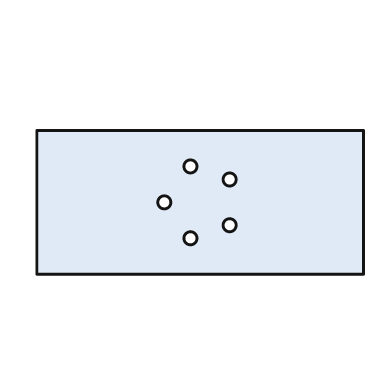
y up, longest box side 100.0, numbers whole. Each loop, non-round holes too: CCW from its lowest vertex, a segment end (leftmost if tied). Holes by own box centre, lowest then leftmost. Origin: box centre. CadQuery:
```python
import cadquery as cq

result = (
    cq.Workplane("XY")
    .moveTo(-50.0, -22.0)
    .lineTo(50.0, -22.0)
    .lineTo(50.0, 22.0)
    .lineTo(-50.0, 22.0)
    .close()
    .moveTo(-3.0, -11.0)
    .circle(2.0)
    .moveTo(9.0, -7.0)
    .circle(2.0)
    .moveTo(-11.0, 0.0)
    .circle(2.0)
    .moveTo(9.0, 7.0)
    .circle(2.0)
    .moveTo(-3.0, 11.0)
    .circle(2.0)
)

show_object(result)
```